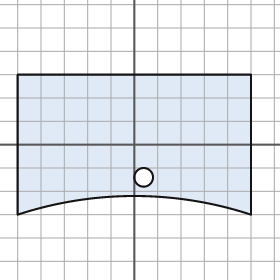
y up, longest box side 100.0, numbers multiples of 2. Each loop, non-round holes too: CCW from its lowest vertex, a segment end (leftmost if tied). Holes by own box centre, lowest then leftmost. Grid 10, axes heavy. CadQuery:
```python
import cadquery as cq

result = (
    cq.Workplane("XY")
    .moveTo(-50.0, -30.0)
    .threePointArc((0.0, -22.0), (50.0, -30.0))
    .lineTo(50.0, 30.0)
    .lineTo(-50.0, 30.0)
    .close()
    .moveTo(4.0, -14.0)
    .circle(4.0)
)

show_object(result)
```